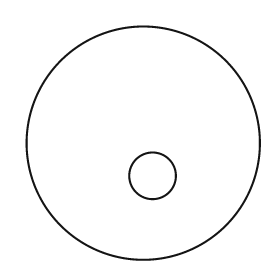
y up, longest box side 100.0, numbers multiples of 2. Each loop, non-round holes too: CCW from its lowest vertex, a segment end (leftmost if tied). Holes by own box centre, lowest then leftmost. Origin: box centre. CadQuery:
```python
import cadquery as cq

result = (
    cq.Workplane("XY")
    .moveTo(0.0, 0.0)
    .circle(50.0)
    .moveTo(4.0, -14.0)
    .circle(10.0)
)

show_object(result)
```